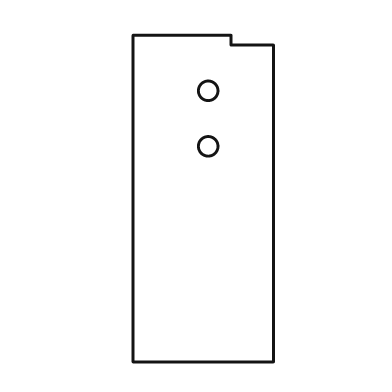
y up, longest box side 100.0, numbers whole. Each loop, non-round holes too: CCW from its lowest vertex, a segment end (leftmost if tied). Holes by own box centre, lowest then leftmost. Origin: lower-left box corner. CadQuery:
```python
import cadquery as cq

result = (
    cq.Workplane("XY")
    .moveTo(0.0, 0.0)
    .lineTo(43.0, 0.0)
    .lineTo(43.0, 97.0)
    .lineTo(30.0, 97.0)
    .lineTo(30.0, 100.0)
    .lineTo(0.0, 100.0)
    .close()
    .moveTo(23.0, 66.0)
    .circle(3.0)
    .moveTo(23.0, 83.0)
    .circle(3.0)
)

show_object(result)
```